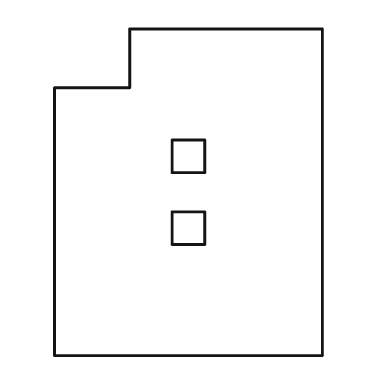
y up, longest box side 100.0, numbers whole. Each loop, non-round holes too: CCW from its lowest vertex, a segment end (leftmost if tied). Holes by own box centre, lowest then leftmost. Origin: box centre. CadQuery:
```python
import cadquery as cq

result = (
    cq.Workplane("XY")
    .moveTo(-41.0, -50.0)
    .lineTo(41.0, -50.0)
    .lineTo(41.0, 50.0)
    .lineTo(-18.0, 50.0)
    .lineTo(-18.0, 32.0)
    .lineTo(-41.0, 32.0)
    .close()
    .moveTo(-5.0, -16.0)
    .lineTo(5.0, -16.0)
    .lineTo(5.0, -6.0)
    .lineTo(-5.0, -6.0)
    .close()
    .moveTo(-5.0, 6.0)
    .lineTo(5.0, 6.0)
    .lineTo(5.0, 16.0)
    .lineTo(-5.0, 16.0)
    .close()
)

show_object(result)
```